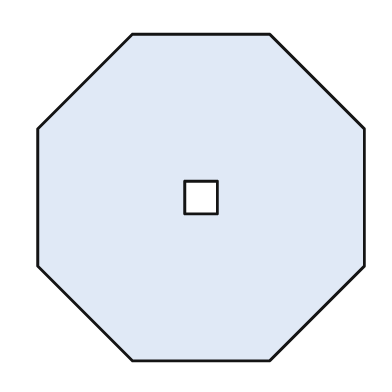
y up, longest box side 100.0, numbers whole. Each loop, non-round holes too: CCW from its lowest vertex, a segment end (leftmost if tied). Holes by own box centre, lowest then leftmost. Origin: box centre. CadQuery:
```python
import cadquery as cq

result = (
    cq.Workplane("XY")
    .moveTo(-21.0, -50.0)
    .lineTo(21.0, -50.0)
    .lineTo(50.0, -21.0)
    .lineTo(50.0, 21.0)
    .lineTo(21.0, 50.0)
    .lineTo(-21.0, 50.0)
    .lineTo(-50.0, 21.0)
    .lineTo(-50.0, -21.0)
    .close()
    .moveTo(-5.0, -5.0)
    .lineTo(5.0, -5.0)
    .lineTo(5.0, 5.0)
    .lineTo(-5.0, 5.0)
    .close()
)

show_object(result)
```